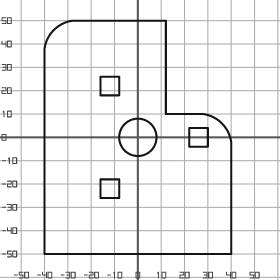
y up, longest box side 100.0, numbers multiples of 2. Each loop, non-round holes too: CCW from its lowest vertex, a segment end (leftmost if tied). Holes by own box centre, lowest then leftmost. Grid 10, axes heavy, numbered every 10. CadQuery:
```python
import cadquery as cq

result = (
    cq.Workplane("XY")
    .moveTo(-40.0, -50.0)
    .lineTo(40.0, -50.0)
    .lineTo(40.0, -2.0)
    .threePointArc((36.0, 6.0), (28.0, 10.0))
    .lineTo(12.0, 10.0)
    .lineTo(12.0, 50.0)
    .lineTo(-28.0, 50.0)
    .threePointArc((-36.0, 46.0), (-40.0, 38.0))
    .close()
    .moveTo(-16.0, -26.0)
    .lineTo(-8.0, -26.0)
    .lineTo(-8.0, -18.0)
    .lineTo(-16.0, -18.0)
    .close()
    .moveTo(0.0, 0.0)
    .circle(8.0)
    .moveTo(22.0, -4.0)
    .lineTo(30.0, -4.0)
    .lineTo(30.0, 4.0)
    .lineTo(22.0, 4.0)
    .close()
    .moveTo(-16.0, 18.0)
    .lineTo(-8.0, 18.0)
    .lineTo(-8.0, 26.0)
    .lineTo(-16.0, 26.0)
    .close()
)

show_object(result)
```